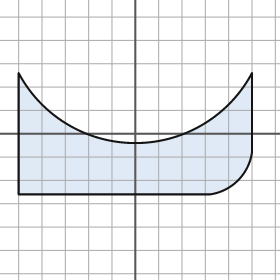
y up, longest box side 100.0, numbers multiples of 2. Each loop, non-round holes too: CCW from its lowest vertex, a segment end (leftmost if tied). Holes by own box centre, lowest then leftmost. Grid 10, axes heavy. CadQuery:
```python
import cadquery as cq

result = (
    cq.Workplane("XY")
    .moveTo(-50.0, -26.0)
    .lineTo(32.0, -26.0)
    .threePointArc((44.0, -20.0), (50.0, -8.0))
    .lineTo(50.0, 26.0)
    .threePointArc((0.0, -4.0), (-50.0, 26.0))
    .close()
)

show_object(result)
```